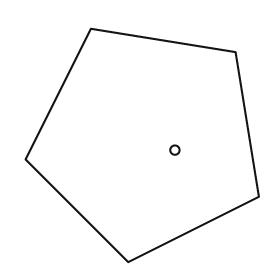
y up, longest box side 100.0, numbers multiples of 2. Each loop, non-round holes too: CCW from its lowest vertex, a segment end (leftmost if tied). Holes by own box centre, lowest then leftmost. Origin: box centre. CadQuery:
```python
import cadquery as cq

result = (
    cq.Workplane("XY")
    .moveTo(-6.0, -50.0)
    .lineTo(50.0, -22.0)
    .lineTo(40.0, 40.0)
    .lineTo(-22.0, 50.0)
    .lineTo(-50.0, -6.0)
    .close()
    .moveTo(14.0, -2.0)
    .circle(2.0)
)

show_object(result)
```